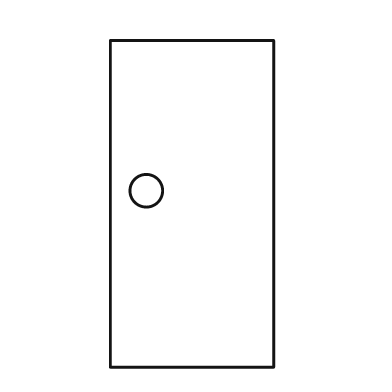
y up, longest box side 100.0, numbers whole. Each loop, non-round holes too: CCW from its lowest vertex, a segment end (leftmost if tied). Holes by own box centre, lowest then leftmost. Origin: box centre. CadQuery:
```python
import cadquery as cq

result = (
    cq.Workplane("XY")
    .moveTo(-25.0, -50.0)
    .lineTo(25.0, -50.0)
    .lineTo(25.0, 50.0)
    .lineTo(-25.0, 50.0)
    .close()
    .moveTo(-14.0, 4.0)
    .circle(5.0)
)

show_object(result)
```